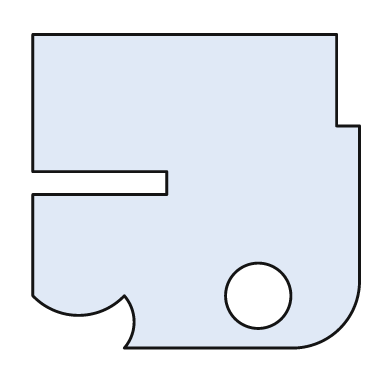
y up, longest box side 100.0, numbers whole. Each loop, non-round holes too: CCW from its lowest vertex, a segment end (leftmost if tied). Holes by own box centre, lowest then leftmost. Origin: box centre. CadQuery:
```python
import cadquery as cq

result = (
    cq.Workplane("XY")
    .moveTo(-22.0, -48.0)
    .lineTo(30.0, -48.0)
    .threePointArc((44.0, -42.0), (50.0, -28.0))
    .lineTo(50.0, 20.0)
    .lineTo(43.0, 20.0)
    .lineTo(43.0, 48.0)
    .lineTo(-50.0, 48.0)
    .lineTo(-50.0, 6.0)
    .lineTo(-9.0, 6.0)
    .lineTo(-9.0, -1.0)
    .lineTo(-50.0, -1.0)
    .lineTo(-50.0, -32.0)
    .threePointArc((-36.0, -38.0), (-22.0, -32.0))
    .threePointArc((-19.0, -40.0), (-22.0, -48.0))
    .close()
    .moveTo(19.0, -32.0)
    .circle(10.0)
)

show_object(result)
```